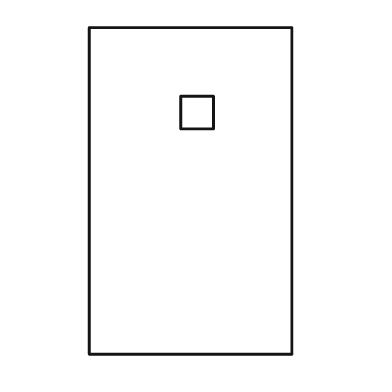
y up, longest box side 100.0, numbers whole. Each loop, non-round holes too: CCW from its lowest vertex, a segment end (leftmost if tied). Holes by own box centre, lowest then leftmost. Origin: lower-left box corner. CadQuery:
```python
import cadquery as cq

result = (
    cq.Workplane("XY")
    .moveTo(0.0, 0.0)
    .lineTo(62.0, 0.0)
    .lineTo(62.0, 100.0)
    .lineTo(0.0, 100.0)
    .close()
    .moveTo(28.0, 69.0)
    .lineTo(38.0, 69.0)
    .lineTo(38.0, 79.0)
    .lineTo(28.0, 79.0)
    .close()
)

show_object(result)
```